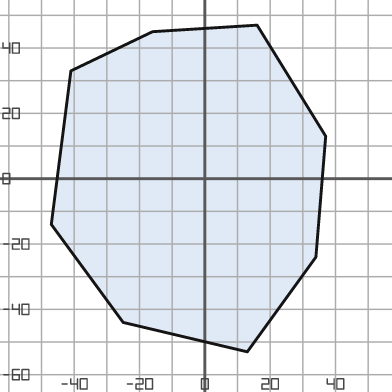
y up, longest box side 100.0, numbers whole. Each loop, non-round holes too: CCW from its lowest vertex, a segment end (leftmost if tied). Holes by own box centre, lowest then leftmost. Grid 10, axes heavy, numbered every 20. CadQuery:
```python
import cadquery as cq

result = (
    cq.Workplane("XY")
    .moveTo(13.0, -53.0)
    .lineTo(34.0, -24.0)
    .lineTo(37.0, 13.0)
    .lineTo(16.0, 47.0)
    .lineTo(-16.0, 45.0)
    .lineTo(-41.0, 33.0)
    .lineTo(-47.0, -14.0)
    .lineTo(-25.0, -44.0)
    .close()
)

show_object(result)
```